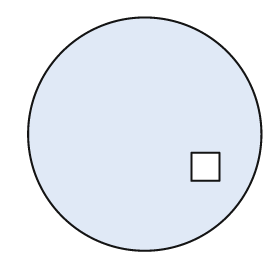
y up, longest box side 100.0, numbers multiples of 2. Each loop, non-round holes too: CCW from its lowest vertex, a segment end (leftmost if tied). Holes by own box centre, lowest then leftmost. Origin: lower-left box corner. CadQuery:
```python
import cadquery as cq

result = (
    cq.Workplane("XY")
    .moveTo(50.0, 50.0)
    .circle(50.0)
    .moveTo(70.0, 30.0)
    .lineTo(82.0, 30.0)
    .lineTo(82.0, 42.0)
    .lineTo(70.0, 42.0)
    .close()
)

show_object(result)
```